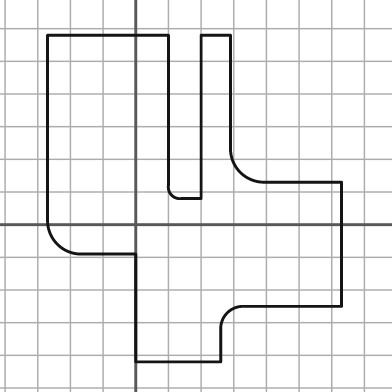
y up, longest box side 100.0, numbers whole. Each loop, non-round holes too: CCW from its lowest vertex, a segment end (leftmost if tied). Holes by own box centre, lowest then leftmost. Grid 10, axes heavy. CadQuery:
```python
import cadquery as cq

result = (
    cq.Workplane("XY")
    .moveTo(0.0, -42.0)
    .lineTo(26.0, -42.0)
    .lineTo(26.0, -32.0)
    .threePointArc((28.0, -27.0), (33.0, -25.0))
    .lineTo(63.0, -25.0)
    .lineTo(63.0, 13.0)
    .lineTo(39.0, 13.0)
    .threePointArc((32.0, 16.0), (29.0, 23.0))
    .lineTo(29.0, 58.0)
    .lineTo(20.0, 58.0)
    .lineTo(20.0, 8.0)
    .lineTo(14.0, 8.0)
    .threePointArc((11.0, 9.0), (10.0, 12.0))
    .lineTo(10.0, 58.0)
    .lineTo(-27.0, 58.0)
    .lineTo(-27.0, 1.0)
    .threePointArc((-24.0, -6.0), (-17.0, -9.0))
    .lineTo(0.0, -9.0)
    .close()
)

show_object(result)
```